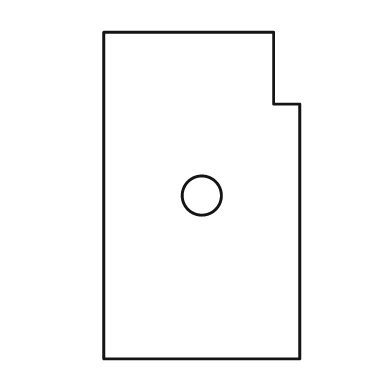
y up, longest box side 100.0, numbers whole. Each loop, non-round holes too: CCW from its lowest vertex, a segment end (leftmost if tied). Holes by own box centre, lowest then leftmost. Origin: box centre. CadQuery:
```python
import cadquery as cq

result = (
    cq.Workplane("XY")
    .moveTo(-30.0, -50.0)
    .lineTo(30.0, -50.0)
    .lineTo(30.0, 28.0)
    .lineTo(22.0, 28.0)
    .lineTo(22.0, 50.0)
    .lineTo(-30.0, 50.0)
    .close()
    .moveTo(0.0, 0.0)
    .circle(6.0)
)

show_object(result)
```